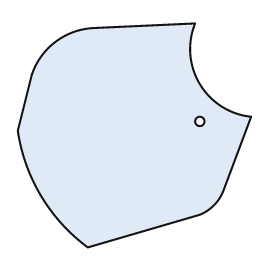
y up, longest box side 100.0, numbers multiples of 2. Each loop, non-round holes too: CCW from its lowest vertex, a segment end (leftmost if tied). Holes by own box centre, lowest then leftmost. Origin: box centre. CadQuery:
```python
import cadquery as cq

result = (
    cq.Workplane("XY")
    .moveTo(-20.0, -48.0)
    .lineTo(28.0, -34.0)
    .threePointArc((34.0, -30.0), (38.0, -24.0))
    .lineTo(50.0, 8.0)
    .threePointArc((28.0, 22.0), (26.0, 48.0))
    .lineTo(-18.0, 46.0)
    .threePointArc((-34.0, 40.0), (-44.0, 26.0))
    .lineTo(-50.0, 2.0)
    .threePointArc((-40.0, -26.0), (-20.0, -48.0))
    .close()
    .moveTo(28.0, 6.0)
    .circle(2.0)
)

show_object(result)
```